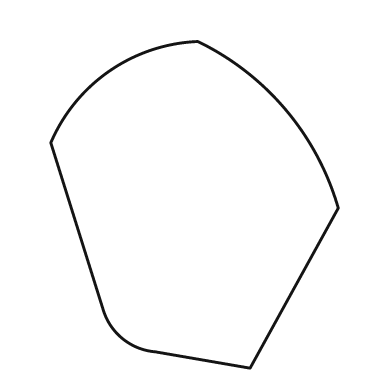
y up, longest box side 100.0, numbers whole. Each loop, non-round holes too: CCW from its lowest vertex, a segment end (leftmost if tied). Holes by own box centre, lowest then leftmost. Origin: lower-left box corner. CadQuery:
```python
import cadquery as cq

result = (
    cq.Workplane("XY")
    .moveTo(61.0, 0.0)
    .lineTo(88.0, 49.0)
    .threePointArc((72.0, 79.0), (45.0, 100.0))
    .threePointArc((18.0, 91.0), (0.0, 69.0))
    .lineTo(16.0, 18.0)
    .threePointArc((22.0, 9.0), (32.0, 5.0))
    .close()
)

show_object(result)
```